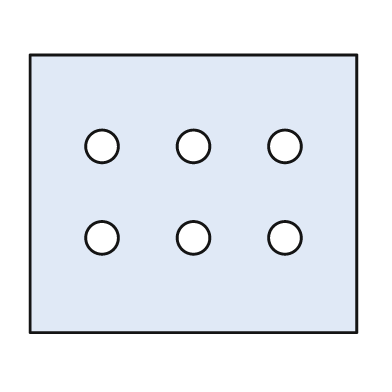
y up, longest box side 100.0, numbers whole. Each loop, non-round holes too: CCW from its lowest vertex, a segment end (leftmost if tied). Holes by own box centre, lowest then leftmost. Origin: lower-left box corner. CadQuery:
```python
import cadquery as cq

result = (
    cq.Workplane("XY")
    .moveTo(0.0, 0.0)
    .lineTo(100.0, 0.0)
    .lineTo(100.0, 85.0)
    .lineTo(0.0, 85.0)
    .close()
    .moveTo(22.0, 29.0)
    .circle(5.0)
    .moveTo(50.0, 29.0)
    .circle(5.0)
    .moveTo(78.0, 29.0)
    .circle(5.0)
    .moveTo(22.0, 57.0)
    .circle(5.0)
    .moveTo(50.0, 57.0)
    .circle(5.0)
    .moveTo(78.0, 57.0)
    .circle(5.0)
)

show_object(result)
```